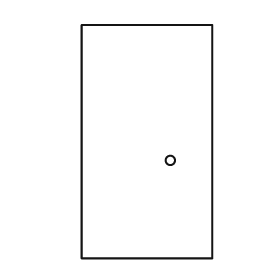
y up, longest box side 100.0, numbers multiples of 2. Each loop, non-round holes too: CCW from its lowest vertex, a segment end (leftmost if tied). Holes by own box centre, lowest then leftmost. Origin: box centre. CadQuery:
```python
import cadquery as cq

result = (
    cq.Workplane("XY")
    .moveTo(-28.0, -50.0)
    .lineTo(28.0, -50.0)
    .lineTo(28.0, 50.0)
    .lineTo(-28.0, 50.0)
    .close()
    .moveTo(10.0, -8.0)
    .circle(2.0)
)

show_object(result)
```